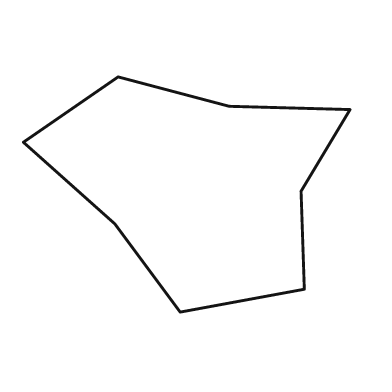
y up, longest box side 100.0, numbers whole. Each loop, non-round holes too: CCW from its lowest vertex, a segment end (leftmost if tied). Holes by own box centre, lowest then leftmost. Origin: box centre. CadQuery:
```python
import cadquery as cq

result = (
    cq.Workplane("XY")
    .moveTo(-2.0, -36.0)
    .lineTo(36.0, -29.0)
    .lineTo(35.0, 1.0)
    .lineTo(50.0, 26.0)
    .lineTo(13.0, 27.0)
    .lineTo(-21.0, 36.0)
    .lineTo(-50.0, 16.0)
    .lineTo(-22.0, -9.0)
    .close()
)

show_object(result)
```